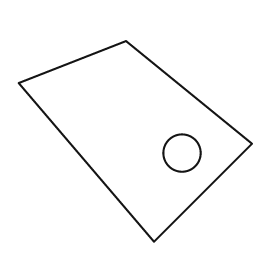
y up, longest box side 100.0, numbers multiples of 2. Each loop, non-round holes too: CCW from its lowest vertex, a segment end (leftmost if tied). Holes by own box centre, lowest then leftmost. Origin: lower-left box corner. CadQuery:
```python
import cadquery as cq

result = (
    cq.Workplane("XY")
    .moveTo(58.0, 0.0)
    .lineTo(100.0, 42.0)
    .lineTo(46.0, 86.0)
    .lineTo(0.0, 68.0)
    .close()
    .moveTo(70.0, 38.0)
    .circle(8.0)
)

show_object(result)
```